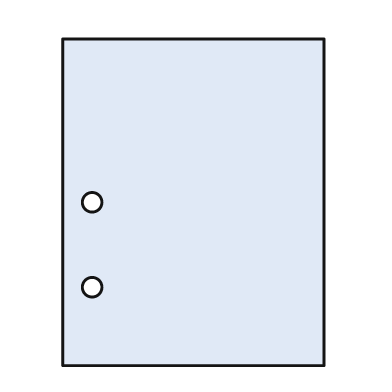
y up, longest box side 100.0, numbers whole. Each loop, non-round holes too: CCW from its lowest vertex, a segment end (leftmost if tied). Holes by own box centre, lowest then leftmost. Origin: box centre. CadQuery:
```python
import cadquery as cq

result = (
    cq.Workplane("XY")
    .moveTo(-40.0, -50.0)
    .lineTo(40.0, -50.0)
    .lineTo(40.0, 50.0)
    .lineTo(-40.0, 50.0)
    .close()
    .moveTo(-31.0, -26.0)
    .circle(3.0)
    .moveTo(-31.0, 0.0)
    .circle(3.0)
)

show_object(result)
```